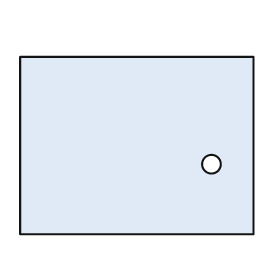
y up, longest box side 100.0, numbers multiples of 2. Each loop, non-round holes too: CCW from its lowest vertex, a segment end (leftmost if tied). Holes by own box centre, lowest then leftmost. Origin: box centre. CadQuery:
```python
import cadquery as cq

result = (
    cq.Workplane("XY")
    .moveTo(-50.0, -38.0)
    .lineTo(50.0, -38.0)
    .lineTo(50.0, 38.0)
    .lineTo(-50.0, 38.0)
    .close()
    .moveTo(32.0, -8.0)
    .circle(4.0)
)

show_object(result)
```